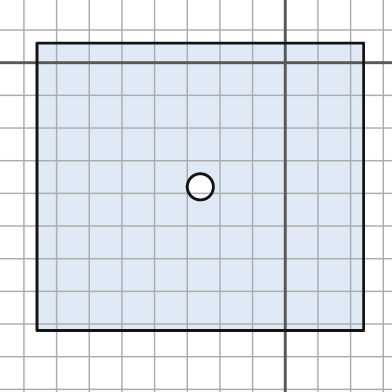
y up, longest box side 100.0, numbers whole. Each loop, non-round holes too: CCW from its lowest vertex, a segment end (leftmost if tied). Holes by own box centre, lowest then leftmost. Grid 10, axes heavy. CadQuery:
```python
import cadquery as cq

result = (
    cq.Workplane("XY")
    .moveTo(-76.0, -82.0)
    .lineTo(24.0, -82.0)
    .lineTo(24.0, 6.0)
    .lineTo(-76.0, 6.0)
    .close()
    .moveTo(-26.0, -38.0)
    .circle(4.0)
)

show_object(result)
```